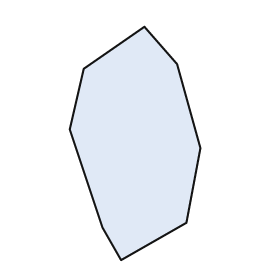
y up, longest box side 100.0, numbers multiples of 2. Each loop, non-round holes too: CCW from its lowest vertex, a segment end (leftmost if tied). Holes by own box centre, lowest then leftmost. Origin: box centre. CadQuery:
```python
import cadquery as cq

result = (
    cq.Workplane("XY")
    .moveTo(-6.0, -50.0)
    .lineTo(22.0, -34.0)
    .lineTo(28.0, -2.0)
    .lineTo(18.0, 34.0)
    .lineTo(4.0, 50.0)
    .lineTo(-22.0, 32.0)
    .lineTo(-28.0, 6.0)
    .lineTo(-14.0, -36.0)
    .close()
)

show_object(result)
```